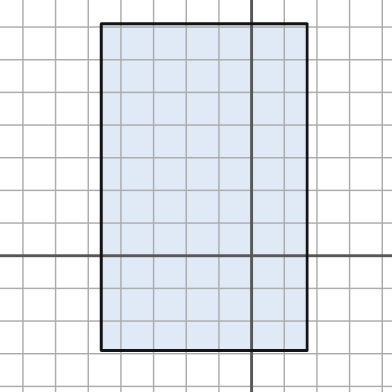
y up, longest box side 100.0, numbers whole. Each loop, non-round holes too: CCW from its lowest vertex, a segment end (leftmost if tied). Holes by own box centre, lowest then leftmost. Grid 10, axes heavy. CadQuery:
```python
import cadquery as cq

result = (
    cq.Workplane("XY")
    .moveTo(-46.0, -29.0)
    .lineTo(17.0, -29.0)
    .lineTo(17.0, 71.0)
    .lineTo(-46.0, 71.0)
    .close()
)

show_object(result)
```